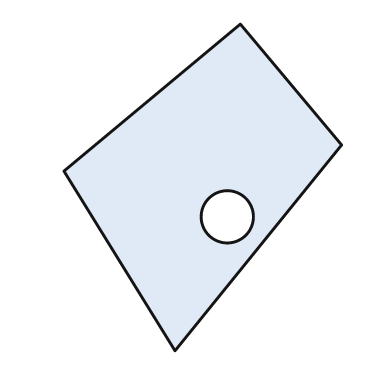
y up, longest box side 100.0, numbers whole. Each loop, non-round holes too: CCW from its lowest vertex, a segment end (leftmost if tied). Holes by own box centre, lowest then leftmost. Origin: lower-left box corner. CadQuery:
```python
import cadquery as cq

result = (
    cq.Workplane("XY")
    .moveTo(34.0, 0.0)
    .lineTo(85.0, 63.0)
    .lineTo(54.0, 100.0)
    .lineTo(0.0, 55.0)
    .close()
    .moveTo(50.0, 41.0)
    .circle(8.0)
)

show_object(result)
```